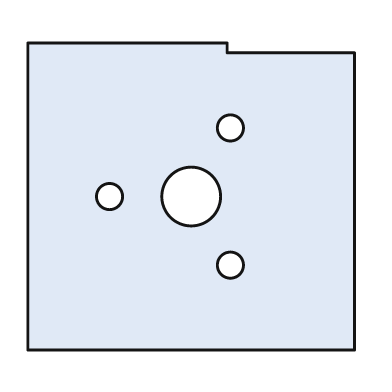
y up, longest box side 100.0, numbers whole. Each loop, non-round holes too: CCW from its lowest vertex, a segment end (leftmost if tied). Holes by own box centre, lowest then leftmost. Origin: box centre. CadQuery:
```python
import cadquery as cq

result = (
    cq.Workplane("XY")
    .moveTo(-50.0, -47.0)
    .lineTo(50.0, -47.0)
    .lineTo(50.0, 44.0)
    .lineTo(11.0, 44.0)
    .lineTo(11.0, 47.0)
    .lineTo(-50.0, 47.0)
    .close()
    .moveTo(12.0, -21.0)
    .circle(4.0)
    .moveTo(-25.0, 0.0)
    .circle(4.0)
    .moveTo(0.0, 0.0)
    .circle(9.0)
    .moveTo(12.0, 21.0)
    .circle(4.0)
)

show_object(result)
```